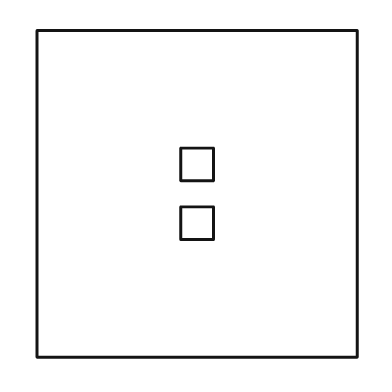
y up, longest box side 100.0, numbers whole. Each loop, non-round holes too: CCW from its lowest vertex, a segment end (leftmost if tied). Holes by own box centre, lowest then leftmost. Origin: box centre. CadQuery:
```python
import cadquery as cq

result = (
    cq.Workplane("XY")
    .moveTo(-49.0, -50.0)
    .lineTo(49.0, -50.0)
    .lineTo(49.0, 50.0)
    .lineTo(-49.0, 50.0)
    .close()
    .moveTo(-5.0, -14.0)
    .lineTo(5.0, -14.0)
    .lineTo(5.0, -4.0)
    .lineTo(-5.0, -4.0)
    .close()
    .moveTo(-5.0, 4.0)
    .lineTo(5.0, 4.0)
    .lineTo(5.0, 14.0)
    .lineTo(-5.0, 14.0)
    .close()
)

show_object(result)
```